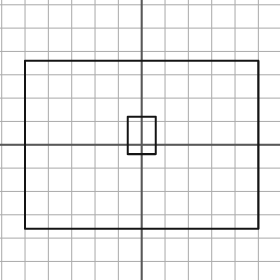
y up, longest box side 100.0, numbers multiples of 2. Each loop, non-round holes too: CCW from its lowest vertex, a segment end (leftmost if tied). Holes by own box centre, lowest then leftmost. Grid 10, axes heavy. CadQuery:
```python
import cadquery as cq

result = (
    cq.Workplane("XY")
    .moveTo(-50.0, -36.0)
    .lineTo(50.0, -36.0)
    .lineTo(50.0, 36.0)
    .lineTo(-50.0, 36.0)
    .close()
    .moveTo(-6.0, -4.0)
    .lineTo(6.0, -4.0)
    .lineTo(6.0, 12.0)
    .lineTo(-6.0, 12.0)
    .close()
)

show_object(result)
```